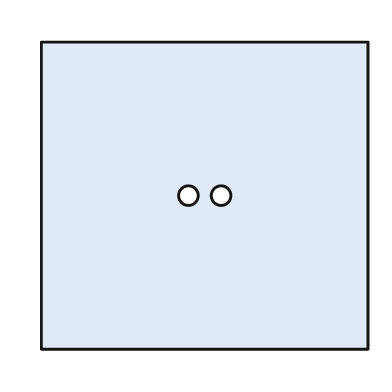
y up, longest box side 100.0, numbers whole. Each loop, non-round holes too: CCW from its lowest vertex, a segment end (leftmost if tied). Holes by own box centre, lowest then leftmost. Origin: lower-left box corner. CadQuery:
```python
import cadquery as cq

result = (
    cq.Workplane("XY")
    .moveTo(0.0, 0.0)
    .lineTo(100.0, 0.0)
    .lineTo(100.0, 94.0)
    .lineTo(0.0, 94.0)
    .close()
    .moveTo(45.0, 47.0)
    .circle(3.0)
    .moveTo(55.0, 47.0)
    .circle(3.0)
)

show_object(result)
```